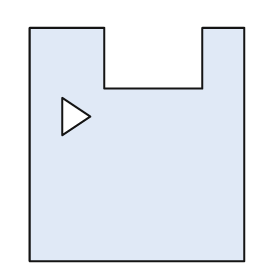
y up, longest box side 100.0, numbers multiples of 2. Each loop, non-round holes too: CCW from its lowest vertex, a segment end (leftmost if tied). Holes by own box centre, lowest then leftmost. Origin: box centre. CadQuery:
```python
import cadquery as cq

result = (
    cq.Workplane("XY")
    .moveTo(-46.0, -50.0)
    .lineTo(46.0, -50.0)
    .lineTo(46.0, 50.0)
    .lineTo(28.0, 50.0)
    .lineTo(28.0, 24.0)
    .lineTo(-14.0, 24.0)
    .lineTo(-14.0, 50.0)
    .lineTo(-46.0, 50.0)
    .close()
    .moveTo(-32.0, 4.0)
    .lineTo(-20.0, 12.0)
    .lineTo(-32.0, 20.0)
    .close()
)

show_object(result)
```